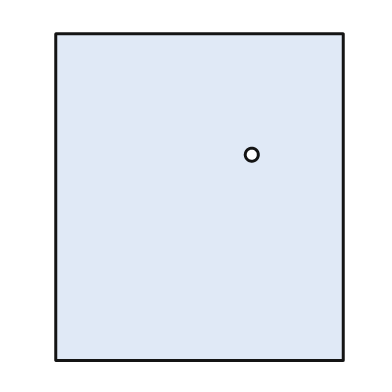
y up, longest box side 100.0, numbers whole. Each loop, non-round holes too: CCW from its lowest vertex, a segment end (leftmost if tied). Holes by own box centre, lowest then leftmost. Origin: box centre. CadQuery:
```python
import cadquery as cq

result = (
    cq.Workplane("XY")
    .moveTo(-44.0, -50.0)
    .lineTo(44.0, -50.0)
    .lineTo(44.0, 50.0)
    .lineTo(-44.0, 50.0)
    .close()
    .moveTo(16.0, 13.0)
    .circle(2.0)
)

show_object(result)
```